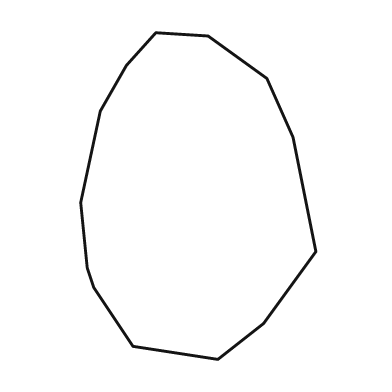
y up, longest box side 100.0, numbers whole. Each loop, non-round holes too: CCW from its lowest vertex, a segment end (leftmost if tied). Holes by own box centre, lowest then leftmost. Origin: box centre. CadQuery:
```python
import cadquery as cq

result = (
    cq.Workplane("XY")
    .moveTo(6.0, -50.0)
    .lineTo(20.0, -39.0)
    .lineTo(36.0, -17.0)
    .lineTo(29.0, 18.0)
    .lineTo(21.0, 36.0)
    .lineTo(3.0, 49.0)
    .lineTo(-13.0, 50.0)
    .lineTo(-22.0, 40.0)
    .lineTo(-30.0, 26.0)
    .lineTo(-36.0, -2.0)
    .lineTo(-34.0, -22.0)
    .lineTo(-32.0, -28.0)
    .lineTo(-20.0, -46.0)
    .close()
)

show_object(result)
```